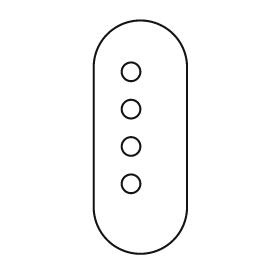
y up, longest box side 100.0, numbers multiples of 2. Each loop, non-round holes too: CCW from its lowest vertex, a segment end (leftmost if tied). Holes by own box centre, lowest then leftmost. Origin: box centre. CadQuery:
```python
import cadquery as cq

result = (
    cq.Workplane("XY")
    .moveTo(-20.0, -30.0)
    .threePointArc((0.0, -50.0), (20.0, -30.0))
    .lineTo(20.0, 30.0)
    .threePointArc((0.0, 50.0), (-20.0, 30.0))
    .close()
    .moveTo(-4.0, -20.0)
    .circle(4.0)
    .moveTo(-4.0, -4.0)
    .circle(4.0)
    .moveTo(-4.0, 12.0)
    .circle(4.0)
    .moveTo(-4.0, 28.0)
    .circle(4.0)
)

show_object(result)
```